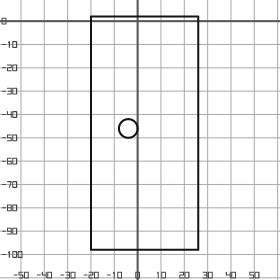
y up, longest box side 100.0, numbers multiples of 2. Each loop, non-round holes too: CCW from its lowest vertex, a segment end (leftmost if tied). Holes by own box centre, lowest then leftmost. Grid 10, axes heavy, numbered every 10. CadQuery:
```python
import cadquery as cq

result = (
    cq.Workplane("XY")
    .moveTo(-20.0, -98.0)
    .lineTo(26.0, -98.0)
    .lineTo(26.0, 2.0)
    .lineTo(-20.0, 2.0)
    .close()
    .moveTo(-4.0, -46.0)
    .circle(4.0)
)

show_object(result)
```